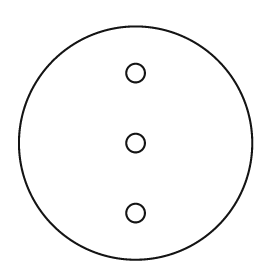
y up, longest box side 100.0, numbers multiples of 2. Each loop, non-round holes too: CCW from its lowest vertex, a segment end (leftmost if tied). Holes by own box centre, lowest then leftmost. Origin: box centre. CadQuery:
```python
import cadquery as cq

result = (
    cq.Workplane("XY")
    .moveTo(0.0, 0.0)
    .circle(50.0)
    .moveTo(0.0, -30.0)
    .circle(4.0)
    .moveTo(0.0, 0.0)
    .circle(4.0)
    .moveTo(0.0, 30.0)
    .circle(4.0)
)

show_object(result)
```